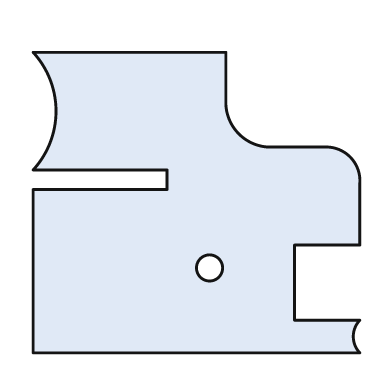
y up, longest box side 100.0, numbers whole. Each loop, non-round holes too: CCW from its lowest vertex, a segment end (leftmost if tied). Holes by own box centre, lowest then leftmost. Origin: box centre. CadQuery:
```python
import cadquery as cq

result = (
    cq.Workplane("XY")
    .moveTo(-50.0, -46.0)
    .lineTo(50.0, -46.0)
    .threePointArc((48.0, -41.0), (50.0, -36.0))
    .lineTo(30.0, -36.0)
    .lineTo(30.0, -13.0)
    .lineTo(50.0, -13.0)
    .lineTo(50.0, 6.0)
    .threePointArc((47.0, 14.0), (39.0, 17.0))
    .lineTo(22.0, 17.0)
    .threePointArc((13.0, 21.0), (9.0, 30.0))
    .lineTo(9.0, 46.0)
    .lineTo(-50.0, 46.0)
    .threePointArc((-43.0, 28.0), (-50.0, 10.0))
    .lineTo(-9.0, 10.0)
    .lineTo(-9.0, 4.0)
    .lineTo(-50.0, 4.0)
    .close()
    .moveTo(4.0, -20.0)
    .circle(4.0)
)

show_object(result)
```